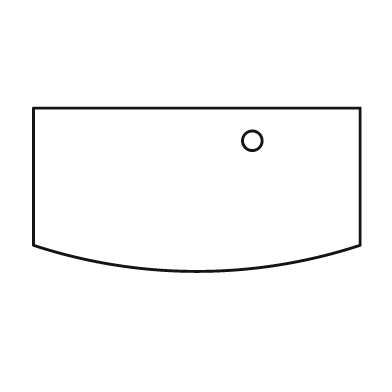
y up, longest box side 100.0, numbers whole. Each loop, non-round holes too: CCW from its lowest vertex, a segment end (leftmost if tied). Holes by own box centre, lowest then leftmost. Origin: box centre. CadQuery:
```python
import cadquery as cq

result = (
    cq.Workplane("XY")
    .moveTo(-50.0, -17.0)
    .threePointArc((0.0, -25.0), (50.0, -17.0))
    .lineTo(50.0, 25.0)
    .lineTo(-50.0, 25.0)
    .close()
    .moveTo(17.0, 15.0)
    .circle(3.0)
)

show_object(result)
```